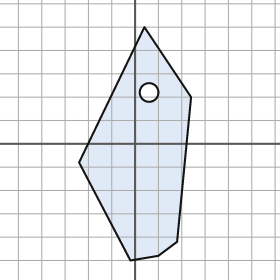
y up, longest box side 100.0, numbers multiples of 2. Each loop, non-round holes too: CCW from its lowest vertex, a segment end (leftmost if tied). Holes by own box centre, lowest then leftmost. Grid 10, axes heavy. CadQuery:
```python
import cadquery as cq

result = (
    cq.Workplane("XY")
    .moveTo(-2.0, -50.0)
    .lineTo(10.0, -48.0)
    .lineTo(18.0, -42.0)
    .lineTo(24.0, 20.0)
    .lineTo(4.0, 50.0)
    .lineTo(-24.0, -8.0)
    .close()
    .moveTo(6.0, 22.0)
    .circle(4.0)
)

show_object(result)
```